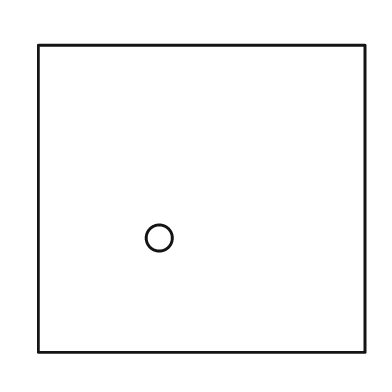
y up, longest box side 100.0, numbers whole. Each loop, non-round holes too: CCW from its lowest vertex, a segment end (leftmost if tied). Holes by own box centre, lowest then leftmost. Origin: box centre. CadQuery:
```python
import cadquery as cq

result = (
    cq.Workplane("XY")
    .moveTo(-50.0, -47.0)
    .lineTo(50.0, -47.0)
    .lineTo(50.0, 47.0)
    .lineTo(-50.0, 47.0)
    .close()
    .moveTo(-13.0, -12.0)
    .circle(4.0)
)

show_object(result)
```